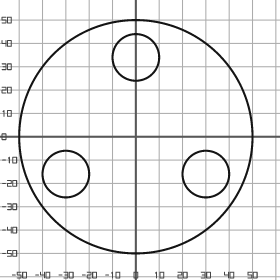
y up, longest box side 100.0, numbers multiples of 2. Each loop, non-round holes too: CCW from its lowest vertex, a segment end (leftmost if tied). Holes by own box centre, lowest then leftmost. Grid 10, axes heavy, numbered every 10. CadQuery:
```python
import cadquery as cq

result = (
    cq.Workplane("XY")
    .moveTo(0.0, 0.0)
    .circle(50.0)
    .moveTo(-30.0, -16.0)
    .circle(10.0)
    .moveTo(30.0, -16.0)
    .circle(10.0)
    .moveTo(0.0, 34.0)
    .circle(10.0)
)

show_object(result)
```